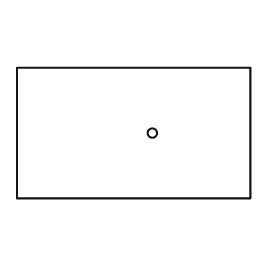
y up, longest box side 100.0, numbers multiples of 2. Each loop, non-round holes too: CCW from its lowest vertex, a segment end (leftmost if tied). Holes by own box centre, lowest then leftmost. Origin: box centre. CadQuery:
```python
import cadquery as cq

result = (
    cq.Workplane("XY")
    .moveTo(-50.0, -28.0)
    .lineTo(50.0, -28.0)
    .lineTo(50.0, 28.0)
    .lineTo(-50.0, 28.0)
    .close()
    .moveTo(8.0, 0.0)
    .circle(2.0)
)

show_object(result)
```